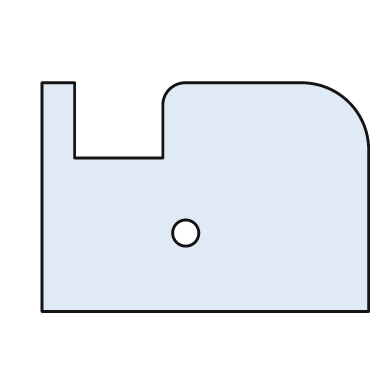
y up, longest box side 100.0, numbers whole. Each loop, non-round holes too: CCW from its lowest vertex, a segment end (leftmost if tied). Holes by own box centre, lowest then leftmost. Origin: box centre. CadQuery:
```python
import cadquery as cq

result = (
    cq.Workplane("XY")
    .moveTo(-50.0, -35.0)
    .lineTo(50.0, -35.0)
    .lineTo(50.0, 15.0)
    .threePointArc((44.0, 29.0), (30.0, 35.0))
    .lineTo(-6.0, 35.0)
    .threePointArc((-11.0, 33.0), (-13.0, 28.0))
    .lineTo(-13.0, 12.0)
    .lineTo(-40.0, 12.0)
    .lineTo(-40.0, 35.0)
    .lineTo(-50.0, 35.0)
    .close()
    .moveTo(-6.0, -11.0)
    .circle(4.0)
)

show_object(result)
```